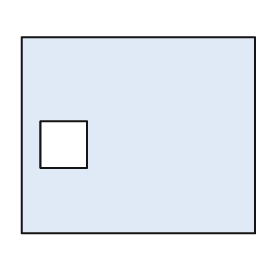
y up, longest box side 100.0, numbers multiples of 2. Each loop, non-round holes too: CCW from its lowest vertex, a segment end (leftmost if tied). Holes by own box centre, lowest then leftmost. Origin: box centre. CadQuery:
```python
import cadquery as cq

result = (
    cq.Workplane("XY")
    .moveTo(-50.0, -42.0)
    .lineTo(50.0, -42.0)
    .lineTo(50.0, 42.0)
    .lineTo(-50.0, 42.0)
    .close()
    .moveTo(-42.0, -14.0)
    .lineTo(-22.0, -14.0)
    .lineTo(-22.0, 6.0)
    .lineTo(-42.0, 6.0)
    .close()
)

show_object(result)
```